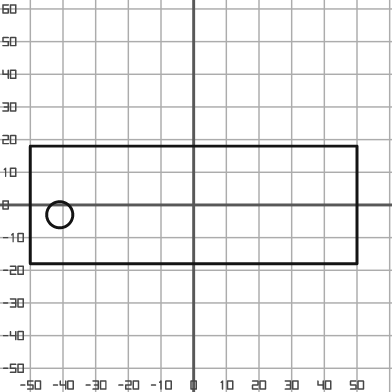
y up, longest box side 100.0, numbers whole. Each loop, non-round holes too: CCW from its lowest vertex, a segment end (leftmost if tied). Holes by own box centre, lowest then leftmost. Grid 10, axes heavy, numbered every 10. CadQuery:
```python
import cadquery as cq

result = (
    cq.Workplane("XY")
    .moveTo(-50.0, -18.0)
    .lineTo(50.0, -18.0)
    .lineTo(50.0, 18.0)
    .lineTo(-50.0, 18.0)
    .close()
    .moveTo(-41.0, -3.0)
    .circle(4.0)
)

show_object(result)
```